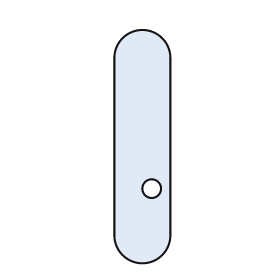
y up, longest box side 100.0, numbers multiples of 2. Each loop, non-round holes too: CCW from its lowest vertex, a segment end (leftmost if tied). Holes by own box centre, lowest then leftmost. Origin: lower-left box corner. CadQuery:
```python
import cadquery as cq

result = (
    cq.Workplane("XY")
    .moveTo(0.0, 12.0)
    .threePointArc((12.0, 0.0), (24.0, 12.0))
    .lineTo(24.0, 88.0)
    .threePointArc((12.0, 100.0), (0.0, 88.0))
    .close()
    .moveTo(16.0, 32.0)
    .circle(4.0)
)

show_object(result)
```